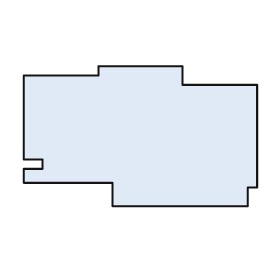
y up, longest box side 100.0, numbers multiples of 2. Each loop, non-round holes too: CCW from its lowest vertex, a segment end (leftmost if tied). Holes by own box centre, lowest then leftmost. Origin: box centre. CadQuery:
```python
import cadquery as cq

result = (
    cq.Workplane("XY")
    .moveTo(-12.0, -30.0)
    .lineTo(46.0, -30.0)
    .lineTo(46.0, -22.0)
    .lineTo(50.0, -22.0)
    .lineTo(50.0, 22.0)
    .lineTo(18.0, 22.0)
    .lineTo(18.0, 30.0)
    .lineTo(-18.0, 30.0)
    .lineTo(-18.0, 26.0)
    .lineTo(-50.0, 26.0)
    .lineTo(-50.0, -10.0)
    .lineTo(-42.0, -10.0)
    .lineTo(-42.0, -14.0)
    .lineTo(-50.0, -14.0)
    .lineTo(-50.0, -20.0)
    .lineTo(-12.0, -20.0)
    .close()
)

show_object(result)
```